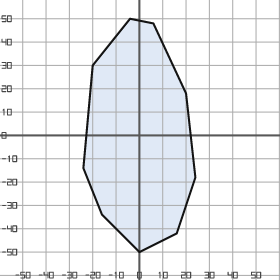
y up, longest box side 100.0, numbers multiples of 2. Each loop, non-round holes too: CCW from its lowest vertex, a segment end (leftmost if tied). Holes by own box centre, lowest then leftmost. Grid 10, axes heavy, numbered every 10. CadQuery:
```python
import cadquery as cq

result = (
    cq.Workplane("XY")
    .moveTo(0.0, -50.0)
    .lineTo(16.0, -42.0)
    .lineTo(24.0, -18.0)
    .lineTo(20.0, 18.0)
    .lineTo(6.0, 48.0)
    .lineTo(-4.0, 50.0)
    .lineTo(-20.0, 30.0)
    .lineTo(-24.0, -14.0)
    .lineTo(-16.0, -34.0)
    .close()
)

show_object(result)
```